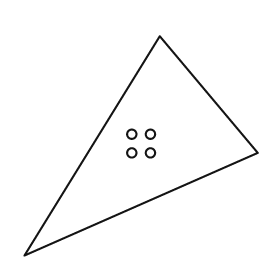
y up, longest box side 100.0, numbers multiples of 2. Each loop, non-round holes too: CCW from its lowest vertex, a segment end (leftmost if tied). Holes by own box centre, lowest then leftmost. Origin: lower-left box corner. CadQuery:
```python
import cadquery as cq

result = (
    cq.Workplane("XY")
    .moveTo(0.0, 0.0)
    .lineTo(100.0, 44.0)
    .lineTo(58.0, 94.0)
    .close()
    .moveTo(46.0, 44.0)
    .circle(2.0)
    .moveTo(54.0, 44.0)
    .circle(2.0)
    .moveTo(46.0, 52.0)
    .circle(2.0)
    .moveTo(54.0, 52.0)
    .circle(2.0)
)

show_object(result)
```